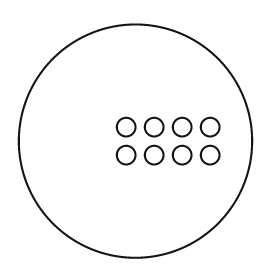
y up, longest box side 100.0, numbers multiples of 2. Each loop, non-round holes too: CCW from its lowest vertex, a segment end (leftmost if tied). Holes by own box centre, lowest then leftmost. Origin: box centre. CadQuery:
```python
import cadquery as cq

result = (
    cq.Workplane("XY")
    .moveTo(0.0, 0.0)
    .circle(50.0)
    .moveTo(-4.0, -6.0)
    .circle(4.0)
    .moveTo(8.0, -6.0)
    .circle(4.0)
    .moveTo(20.0, -6.0)
    .circle(4.0)
    .moveTo(32.0, -6.0)
    .circle(4.0)
    .moveTo(-4.0, 6.0)
    .circle(4.0)
    .moveTo(8.0, 6.0)
    .circle(4.0)
    .moveTo(20.0, 6.0)
    .circle(4.0)
    .moveTo(32.0, 6.0)
    .circle(4.0)
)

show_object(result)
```